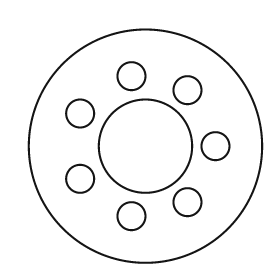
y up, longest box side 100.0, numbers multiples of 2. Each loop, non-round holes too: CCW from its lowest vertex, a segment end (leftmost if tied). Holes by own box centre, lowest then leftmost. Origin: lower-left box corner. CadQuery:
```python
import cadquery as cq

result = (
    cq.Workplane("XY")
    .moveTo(50.0, 50.0)
    .circle(50.0)
    .moveTo(44.0, 20.0)
    .circle(6.0)
    .moveTo(68.0, 26.0)
    .circle(6.0)
    .moveTo(22.0, 36.0)
    .circle(6.0)
    .moveTo(50.0, 50.0)
    .circle(20.0)
    .moveTo(80.0, 50.0)
    .circle(6.0)
    .moveTo(22.0, 64.0)
    .circle(6.0)
    .moveTo(68.0, 74.0)
    .circle(6.0)
    .moveTo(44.0, 80.0)
    .circle(6.0)
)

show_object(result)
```